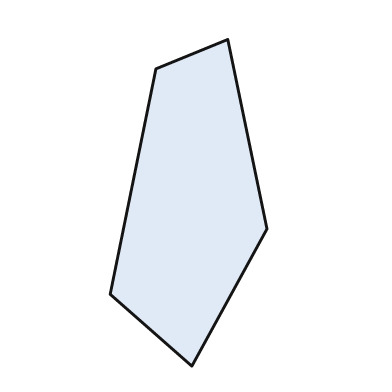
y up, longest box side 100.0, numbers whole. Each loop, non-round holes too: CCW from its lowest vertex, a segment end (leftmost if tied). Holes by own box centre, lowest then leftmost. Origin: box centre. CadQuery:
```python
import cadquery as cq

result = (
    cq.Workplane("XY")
    .moveTo(1.0, -50.0)
    .lineTo(24.0, -8.0)
    .lineTo(12.0, 50.0)
    .lineTo(-10.0, 41.0)
    .lineTo(-24.0, -28.0)
    .close()
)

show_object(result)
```